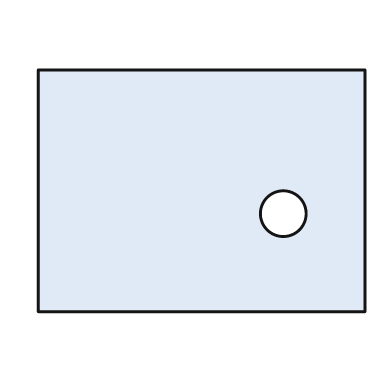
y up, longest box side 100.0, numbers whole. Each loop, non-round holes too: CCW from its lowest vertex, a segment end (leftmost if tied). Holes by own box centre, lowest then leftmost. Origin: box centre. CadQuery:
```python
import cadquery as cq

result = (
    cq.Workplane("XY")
    .moveTo(-50.0, -37.0)
    .lineTo(50.0, -37.0)
    .lineTo(50.0, 37.0)
    .lineTo(-50.0, 37.0)
    .close()
    .moveTo(25.0, -7.0)
    .circle(7.0)
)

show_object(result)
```